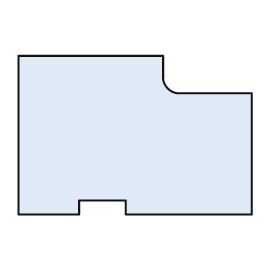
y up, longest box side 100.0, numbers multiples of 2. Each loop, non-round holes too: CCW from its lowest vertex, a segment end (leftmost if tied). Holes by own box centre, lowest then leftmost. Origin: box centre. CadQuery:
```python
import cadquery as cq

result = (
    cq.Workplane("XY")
    .moveTo(-50.0, -34.0)
    .lineTo(-24.0, -34.0)
    .lineTo(-24.0, -28.0)
    .lineTo(-4.0, -28.0)
    .lineTo(-4.0, -34.0)
    .lineTo(50.0, -34.0)
    .lineTo(50.0, 18.0)
    .lineTo(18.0, 18.0)
    .threePointArc((14.0, 20.0), (12.0, 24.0))
    .lineTo(12.0, 34.0)
    .lineTo(-50.0, 34.0)
    .close()
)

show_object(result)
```